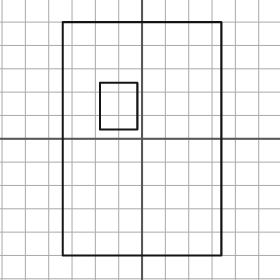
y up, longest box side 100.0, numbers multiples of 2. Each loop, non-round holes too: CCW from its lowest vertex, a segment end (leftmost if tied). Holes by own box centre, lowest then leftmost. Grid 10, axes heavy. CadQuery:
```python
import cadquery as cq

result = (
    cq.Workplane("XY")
    .moveTo(-34.0, -50.0)
    .lineTo(34.0, -50.0)
    .lineTo(34.0, 50.0)
    .lineTo(-34.0, 50.0)
    .close()
    .moveTo(-18.0, 4.0)
    .lineTo(-2.0, 4.0)
    .lineTo(-2.0, 24.0)
    .lineTo(-18.0, 24.0)
    .close()
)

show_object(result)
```